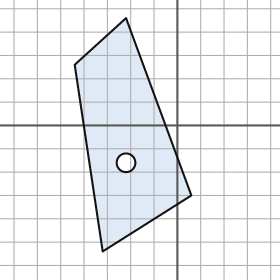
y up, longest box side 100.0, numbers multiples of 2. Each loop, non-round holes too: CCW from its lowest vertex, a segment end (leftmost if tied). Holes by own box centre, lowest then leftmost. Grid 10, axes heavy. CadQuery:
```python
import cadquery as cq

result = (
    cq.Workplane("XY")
    .moveTo(-32.0, -54.0)
    .lineTo(6.0, -30.0)
    .lineTo(-22.0, 46.0)
    .lineTo(-44.0, 26.0)
    .close()
    .moveTo(-22.0, -16.0)
    .circle(4.0)
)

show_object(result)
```